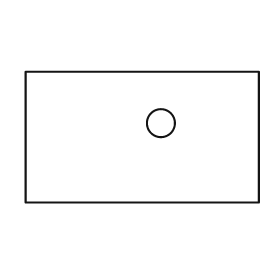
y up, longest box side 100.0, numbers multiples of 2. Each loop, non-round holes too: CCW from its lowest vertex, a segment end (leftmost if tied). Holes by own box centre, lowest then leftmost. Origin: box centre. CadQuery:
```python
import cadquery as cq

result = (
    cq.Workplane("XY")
    .moveTo(-50.0, -28.0)
    .lineTo(50.0, -28.0)
    .lineTo(50.0, 28.0)
    .lineTo(-50.0, 28.0)
    .close()
    .moveTo(8.0, 6.0)
    .circle(6.0)
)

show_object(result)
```